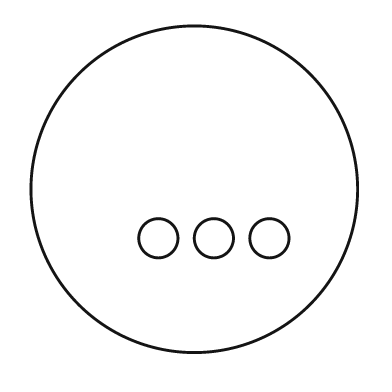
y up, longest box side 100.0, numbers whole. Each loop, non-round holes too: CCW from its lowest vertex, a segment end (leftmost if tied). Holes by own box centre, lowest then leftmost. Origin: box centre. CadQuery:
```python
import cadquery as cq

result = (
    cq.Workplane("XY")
    .moveTo(0.0, 0.0)
    .circle(50.0)
    .moveTo(-11.0, -15.0)
    .circle(6.0)
    .moveTo(6.0, -15.0)
    .circle(6.0)
    .moveTo(23.0, -15.0)
    .circle(6.0)
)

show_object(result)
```